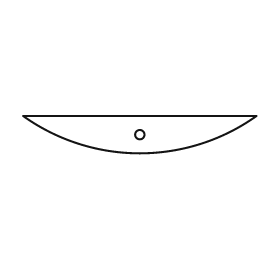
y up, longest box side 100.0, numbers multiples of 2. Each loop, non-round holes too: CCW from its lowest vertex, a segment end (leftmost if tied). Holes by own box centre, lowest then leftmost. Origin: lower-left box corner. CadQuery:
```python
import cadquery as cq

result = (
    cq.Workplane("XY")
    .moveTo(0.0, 16.0)
    .threePointArc((50.0, 0.0), (100.0, 16.0))
    .close()
    .moveTo(50.0, 8.0)
    .circle(2.0)
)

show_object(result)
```